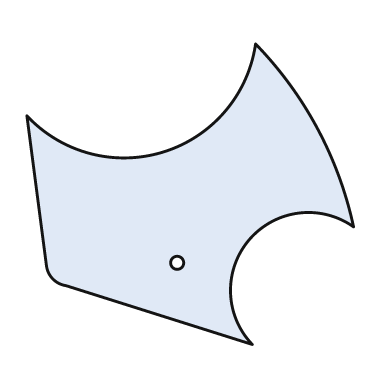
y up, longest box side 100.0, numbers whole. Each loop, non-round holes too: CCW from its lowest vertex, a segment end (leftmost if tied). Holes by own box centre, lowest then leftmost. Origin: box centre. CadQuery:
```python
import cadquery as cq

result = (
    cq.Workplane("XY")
    .moveTo(19.0, -46.0)
    .threePointArc((18.0, -14.0), (50.0, -10.0))
    .threePointArc((39.0, 20.0), (20.0, 46.0))
    .threePointArc((-8.0, 13.0), (-50.0, 24.0))
    .lineTo(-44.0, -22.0)
    .threePointArc((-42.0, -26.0), (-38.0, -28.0))
    .close()
    .moveTo(-4.0, -21.0)
    .circle(2.0)
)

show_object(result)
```